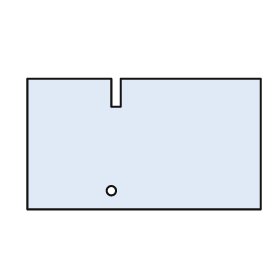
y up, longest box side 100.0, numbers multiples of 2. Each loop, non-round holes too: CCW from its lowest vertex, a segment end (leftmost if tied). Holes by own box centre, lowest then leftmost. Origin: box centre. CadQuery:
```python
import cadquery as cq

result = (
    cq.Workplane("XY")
    .moveTo(-50.0, -28.0)
    .lineTo(50.0, -28.0)
    .lineTo(50.0, 28.0)
    .lineTo(-10.0, 28.0)
    .lineTo(-10.0, 16.0)
    .lineTo(-14.0, 16.0)
    .lineTo(-14.0, 28.0)
    .lineTo(-50.0, 28.0)
    .close()
    .moveTo(-14.0, -20.0)
    .circle(2.0)
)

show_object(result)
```